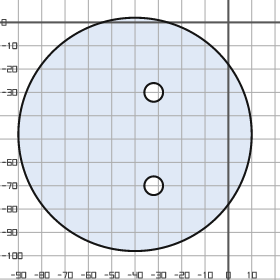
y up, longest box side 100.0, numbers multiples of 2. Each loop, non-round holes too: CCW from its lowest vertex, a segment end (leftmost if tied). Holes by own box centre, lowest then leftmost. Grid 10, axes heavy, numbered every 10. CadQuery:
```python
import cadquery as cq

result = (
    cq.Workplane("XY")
    .moveTo(-40.0, -48.0)
    .circle(50.0)
    .moveTo(-32.0, -70.0)
    .circle(4.0)
    .moveTo(-32.0, -30.0)
    .circle(4.0)
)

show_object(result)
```